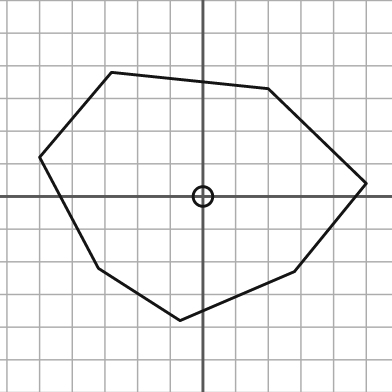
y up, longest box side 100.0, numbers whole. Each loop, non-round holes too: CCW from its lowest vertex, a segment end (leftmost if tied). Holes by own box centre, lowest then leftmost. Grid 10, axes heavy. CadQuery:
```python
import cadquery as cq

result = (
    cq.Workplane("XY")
    .moveTo(-7.0, -38.0)
    .lineTo(28.0, -23.0)
    .lineTo(50.0, 4.0)
    .lineTo(20.0, 33.0)
    .lineTo(-28.0, 38.0)
    .lineTo(-50.0, 12.0)
    .lineTo(-32.0, -22.0)
    .close()
    .moveTo(0.0, 0.0)
    .circle(3.0)
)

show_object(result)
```